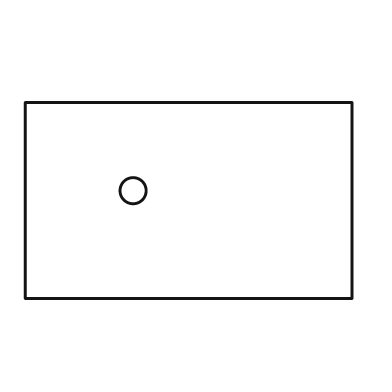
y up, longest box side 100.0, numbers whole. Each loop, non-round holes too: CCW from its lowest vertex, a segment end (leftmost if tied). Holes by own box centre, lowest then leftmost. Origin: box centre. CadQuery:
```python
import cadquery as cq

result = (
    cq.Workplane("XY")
    .moveTo(-50.0, -30.0)
    .lineTo(50.0, -30.0)
    .lineTo(50.0, 30.0)
    .lineTo(-50.0, 30.0)
    .close()
    .moveTo(-17.0, 3.0)
    .circle(4.0)
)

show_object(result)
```